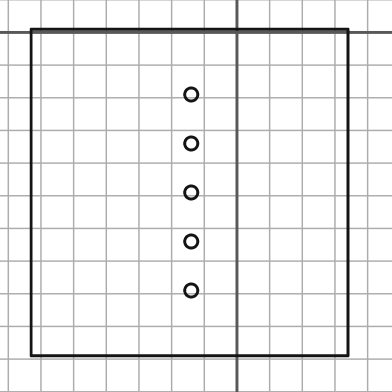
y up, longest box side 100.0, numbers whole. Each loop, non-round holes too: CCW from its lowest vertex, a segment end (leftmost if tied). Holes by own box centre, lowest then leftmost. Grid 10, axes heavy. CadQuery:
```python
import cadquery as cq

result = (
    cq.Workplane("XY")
    .moveTo(-63.0, -99.0)
    .lineTo(34.0, -99.0)
    .lineTo(34.0, 1.0)
    .lineTo(-63.0, 1.0)
    .close()
    .moveTo(-14.0, -79.0)
    .circle(2.0)
    .moveTo(-14.0, -64.0)
    .circle(2.0)
    .moveTo(-14.0, -49.0)
    .circle(2.0)
    .moveTo(-14.0, -34.0)
    .circle(2.0)
    .moveTo(-14.0, -19.0)
    .circle(2.0)
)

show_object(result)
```